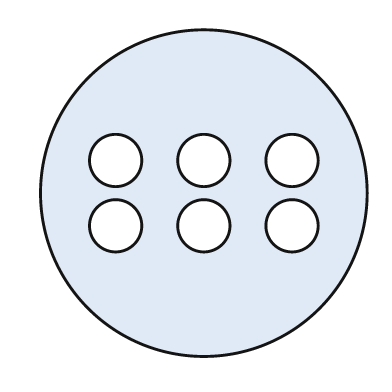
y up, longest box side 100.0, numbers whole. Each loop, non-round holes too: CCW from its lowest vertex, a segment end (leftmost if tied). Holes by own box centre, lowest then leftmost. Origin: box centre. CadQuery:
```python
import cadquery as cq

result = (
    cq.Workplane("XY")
    .moveTo(0.0, 0.0)
    .circle(50.0)
    .moveTo(-27.0, -10.0)
    .circle(8.0)
    .moveTo(0.0, -10.0)
    .circle(8.0)
    .moveTo(27.0, -10.0)
    .circle(8.0)
    .moveTo(-27.0, 10.0)
    .circle(8.0)
    .moveTo(0.0, 10.0)
    .circle(8.0)
    .moveTo(27.0, 10.0)
    .circle(8.0)
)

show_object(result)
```